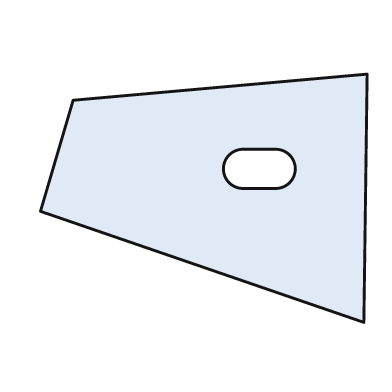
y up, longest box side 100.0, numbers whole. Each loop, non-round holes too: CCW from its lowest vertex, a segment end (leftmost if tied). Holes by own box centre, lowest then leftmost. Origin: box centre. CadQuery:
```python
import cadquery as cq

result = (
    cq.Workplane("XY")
    .moveTo(49.0, -38.0)
    .lineTo(50.0, 38.0)
    .lineTo(-40.0, 30.0)
    .lineTo(-50.0, -4.0)
    .close()
    .moveTo(12.0, 3.0)
    .lineTo(22.0, 3.0)
    .threePointArc((28.0, 9.0), (22.0, 15.0))
    .lineTo(12.0, 15.0)
    .threePointArc((6.0, 9.0), (12.0, 3.0))
    .close()
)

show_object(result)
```